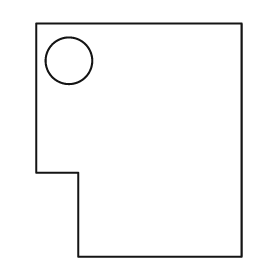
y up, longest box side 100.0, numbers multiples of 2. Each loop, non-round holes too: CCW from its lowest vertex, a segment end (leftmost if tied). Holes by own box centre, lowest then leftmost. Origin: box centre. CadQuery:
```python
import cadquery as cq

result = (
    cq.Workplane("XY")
    .moveTo(-26.0, -50.0)
    .lineTo(44.0, -50.0)
    .lineTo(44.0, 50.0)
    .lineTo(-44.0, 50.0)
    .lineTo(-44.0, -14.0)
    .lineTo(-26.0, -14.0)
    .close()
    .moveTo(-30.0, 34.0)
    .circle(10.0)
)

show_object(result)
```